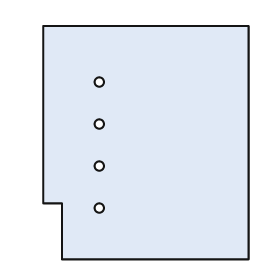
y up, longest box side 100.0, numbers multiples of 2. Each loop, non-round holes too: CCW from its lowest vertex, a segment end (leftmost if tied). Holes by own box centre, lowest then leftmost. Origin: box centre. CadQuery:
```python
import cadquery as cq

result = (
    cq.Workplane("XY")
    .moveTo(-36.0, -50.0)
    .lineTo(44.0, -50.0)
    .lineTo(44.0, 50.0)
    .lineTo(-44.0, 50.0)
    .lineTo(-44.0, -26.0)
    .lineTo(-36.0, -26.0)
    .close()
    .moveTo(-20.0, -28.0)
    .circle(2.0)
    .moveTo(-20.0, -10.0)
    .circle(2.0)
    .moveTo(-20.0, 8.0)
    .circle(2.0)
    .moveTo(-20.0, 26.0)
    .circle(2.0)
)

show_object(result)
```